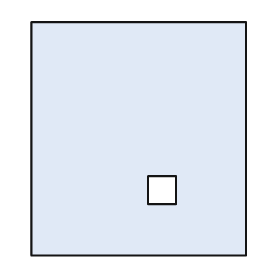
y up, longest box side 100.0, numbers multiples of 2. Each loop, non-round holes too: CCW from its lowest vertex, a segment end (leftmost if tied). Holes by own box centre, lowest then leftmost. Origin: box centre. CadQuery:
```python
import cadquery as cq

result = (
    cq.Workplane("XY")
    .moveTo(-46.0, -50.0)
    .lineTo(46.0, -50.0)
    .lineTo(46.0, 50.0)
    .lineTo(-46.0, 50.0)
    .close()
    .moveTo(4.0, -28.0)
    .lineTo(16.0, -28.0)
    .lineTo(16.0, -16.0)
    .lineTo(4.0, -16.0)
    .close()
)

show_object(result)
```